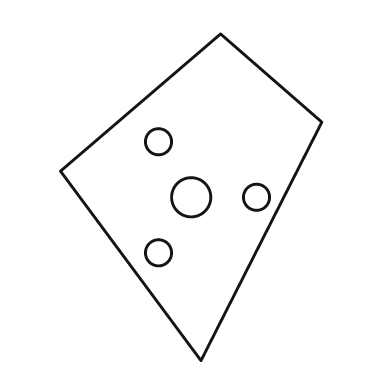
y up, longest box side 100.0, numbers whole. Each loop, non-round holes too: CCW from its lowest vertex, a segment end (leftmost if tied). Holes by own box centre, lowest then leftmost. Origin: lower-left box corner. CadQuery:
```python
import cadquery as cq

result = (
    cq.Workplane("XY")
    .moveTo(43.0, 0.0)
    .lineTo(80.0, 73.0)
    .lineTo(49.0, 100.0)
    .lineTo(0.0, 58.0)
    .close()
    .moveTo(30.0, 33.0)
    .circle(4.0)
    .moveTo(40.0, 50.0)
    .circle(6.0)
    .moveTo(60.0, 50.0)
    .circle(4.0)
    .moveTo(30.0, 67.0)
    .circle(4.0)
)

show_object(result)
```